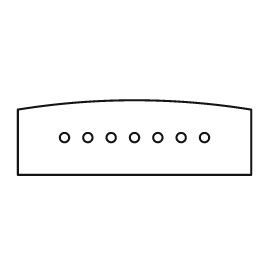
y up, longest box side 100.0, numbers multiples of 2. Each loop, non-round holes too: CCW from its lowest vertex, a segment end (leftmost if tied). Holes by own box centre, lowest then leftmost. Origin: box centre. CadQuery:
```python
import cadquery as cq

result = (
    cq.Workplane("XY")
    .moveTo(-50.0, -16.0)
    .lineTo(50.0, -16.0)
    .lineTo(50.0, 12.0)
    .threePointArc((0.0, 16.0), (-50.0, 12.0))
    .close()
    .moveTo(-30.0, 0.0)
    .circle(2.0)
    .moveTo(-20.0, 0.0)
    .circle(2.0)
    .moveTo(-10.0, 0.0)
    .circle(2.0)
    .moveTo(0.0, 0.0)
    .circle(2.0)
    .moveTo(10.0, 0.0)
    .circle(2.0)
    .moveTo(20.0, 0.0)
    .circle(2.0)
    .moveTo(30.0, 0.0)
    .circle(2.0)
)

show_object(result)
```